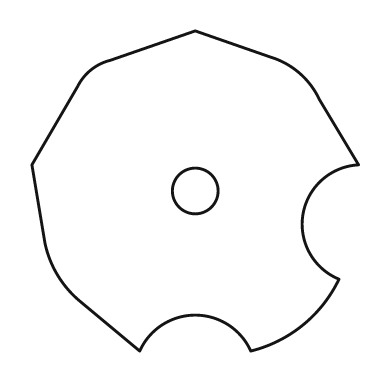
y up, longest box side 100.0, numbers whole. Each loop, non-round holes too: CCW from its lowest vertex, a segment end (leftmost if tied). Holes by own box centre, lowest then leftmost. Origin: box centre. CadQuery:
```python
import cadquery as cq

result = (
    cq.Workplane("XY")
    .moveTo(-17.0, -49.0)
    .threePointArc((0.0, -38.0), (17.0, -49.0))
    .threePointArc((33.0, -41.0), (44.0, -27.0))
    .threePointArc((33.0, -7.0), (50.0, 8.0))
    .lineTo(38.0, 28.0)
    .threePointArc((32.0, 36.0), (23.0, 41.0))
    .lineTo(0.0, 49.0)
    .lineTo(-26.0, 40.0)
    .threePointArc((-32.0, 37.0), (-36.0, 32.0))
    .lineTo(-50.0, 8.0)
    .lineTo(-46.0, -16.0)
    .threePointArc((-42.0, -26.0), (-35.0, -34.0))
    .close()
    .moveTo(0.0, 0.0)
    .circle(7.0)
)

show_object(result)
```